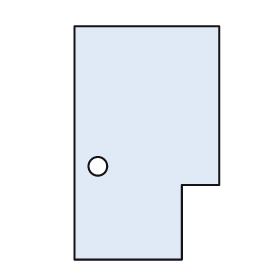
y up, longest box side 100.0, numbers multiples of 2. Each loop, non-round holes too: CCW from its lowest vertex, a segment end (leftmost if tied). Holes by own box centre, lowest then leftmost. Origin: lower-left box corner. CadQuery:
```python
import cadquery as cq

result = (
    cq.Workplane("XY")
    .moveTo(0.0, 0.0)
    .lineTo(46.0, 0.0)
    .lineTo(46.0, 32.0)
    .lineTo(62.0, 32.0)
    .lineTo(62.0, 100.0)
    .lineTo(0.0, 100.0)
    .close()
    .moveTo(10.0, 40.0)
    .circle(4.0)
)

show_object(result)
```